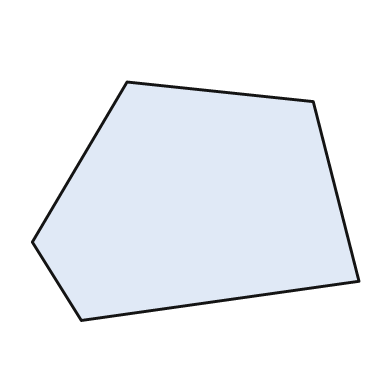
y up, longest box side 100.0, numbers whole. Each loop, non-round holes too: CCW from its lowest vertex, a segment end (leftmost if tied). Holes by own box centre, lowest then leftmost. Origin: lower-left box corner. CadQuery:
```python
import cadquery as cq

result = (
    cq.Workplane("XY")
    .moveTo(15.0, 0.0)
    .lineTo(100.0, 12.0)
    .lineTo(86.0, 67.0)
    .lineTo(29.0, 73.0)
    .lineTo(0.0, 24.0)
    .close()
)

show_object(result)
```